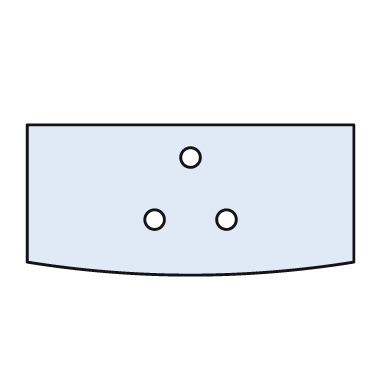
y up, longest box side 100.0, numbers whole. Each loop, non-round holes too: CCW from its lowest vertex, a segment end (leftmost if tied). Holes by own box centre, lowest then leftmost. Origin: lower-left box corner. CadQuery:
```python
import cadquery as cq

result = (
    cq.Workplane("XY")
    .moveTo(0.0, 4.0)
    .threePointArc((50.0, 0.0), (100.0, 4.0))
    .lineTo(100.0, 46.0)
    .lineTo(0.0, 46.0)
    .close()
    .moveTo(39.0, 17.0)
    .circle(3.0)
    .moveTo(61.0, 17.0)
    .circle(3.0)
    .moveTo(50.0, 36.0)
    .circle(3.0)
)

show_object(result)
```